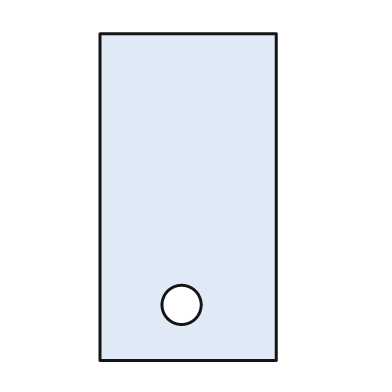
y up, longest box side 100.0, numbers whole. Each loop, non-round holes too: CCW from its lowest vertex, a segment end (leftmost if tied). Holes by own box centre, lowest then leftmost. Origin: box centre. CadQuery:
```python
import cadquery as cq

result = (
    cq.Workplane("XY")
    .moveTo(-27.0, -50.0)
    .lineTo(27.0, -50.0)
    .lineTo(27.0, 50.0)
    .lineTo(-27.0, 50.0)
    .close()
    .moveTo(-2.0, -33.0)
    .circle(6.0)
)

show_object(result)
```